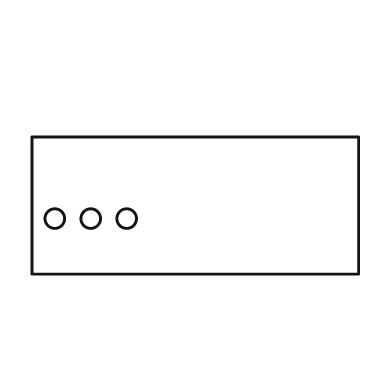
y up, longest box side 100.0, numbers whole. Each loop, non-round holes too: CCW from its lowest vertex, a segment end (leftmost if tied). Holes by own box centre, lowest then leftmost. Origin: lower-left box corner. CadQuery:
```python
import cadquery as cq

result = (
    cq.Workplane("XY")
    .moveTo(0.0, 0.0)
    .lineTo(100.0, 0.0)
    .lineTo(100.0, 42.0)
    .lineTo(0.0, 42.0)
    .close()
    .moveTo(7.0, 17.0)
    .circle(3.0)
    .moveTo(18.0, 17.0)
    .circle(3.0)
    .moveTo(29.0, 17.0)
    .circle(3.0)
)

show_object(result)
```